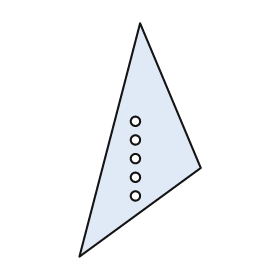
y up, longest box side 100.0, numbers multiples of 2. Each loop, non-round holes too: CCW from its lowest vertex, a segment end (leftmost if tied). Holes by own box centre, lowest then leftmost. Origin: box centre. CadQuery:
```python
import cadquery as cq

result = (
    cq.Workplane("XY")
    .moveTo(-26.0, -50.0)
    .lineTo(26.0, -12.0)
    .lineTo(0.0, 50.0)
    .close()
    .moveTo(-2.0, -24.0)
    .circle(2.0)
    .moveTo(-2.0, -16.0)
    .circle(2.0)
    .moveTo(-2.0, -8.0)
    .circle(2.0)
    .moveTo(-2.0, 0.0)
    .circle(2.0)
    .moveTo(-2.0, 8.0)
    .circle(2.0)
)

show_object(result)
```